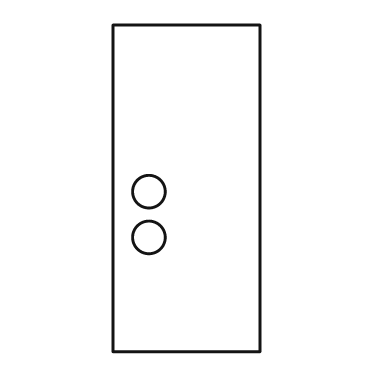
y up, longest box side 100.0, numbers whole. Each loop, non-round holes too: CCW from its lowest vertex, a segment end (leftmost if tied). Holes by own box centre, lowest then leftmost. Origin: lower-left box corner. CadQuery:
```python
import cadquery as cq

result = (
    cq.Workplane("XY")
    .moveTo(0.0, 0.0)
    .lineTo(45.0, 0.0)
    .lineTo(45.0, 100.0)
    .lineTo(0.0, 100.0)
    .close()
    .moveTo(11.0, 35.0)
    .circle(5.0)
    .moveTo(11.0, 49.0)
    .circle(5.0)
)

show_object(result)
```